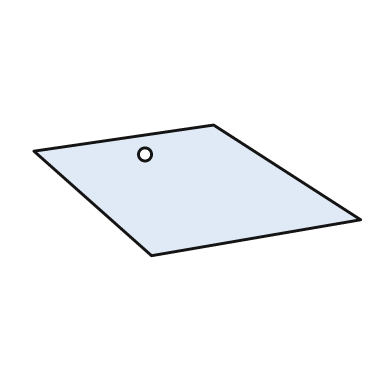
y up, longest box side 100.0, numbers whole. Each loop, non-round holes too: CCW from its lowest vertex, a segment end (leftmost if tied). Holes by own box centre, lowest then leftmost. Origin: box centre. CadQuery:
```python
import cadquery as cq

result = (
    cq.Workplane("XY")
    .moveTo(-14.0, -20.0)
    .lineTo(50.0, -9.0)
    .lineTo(5.0, 20.0)
    .lineTo(-50.0, 12.0)
    .close()
    .moveTo(-16.0, 11.0)
    .circle(2.0)
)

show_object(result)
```